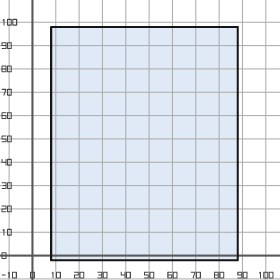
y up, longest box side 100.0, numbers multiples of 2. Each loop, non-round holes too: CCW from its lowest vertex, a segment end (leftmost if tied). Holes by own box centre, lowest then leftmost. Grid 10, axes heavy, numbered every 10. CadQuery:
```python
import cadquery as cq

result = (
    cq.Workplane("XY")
    .moveTo(8.0, -2.0)
    .lineTo(88.0, -2.0)
    .lineTo(88.0, 98.0)
    .lineTo(8.0, 98.0)
    .close()
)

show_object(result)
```